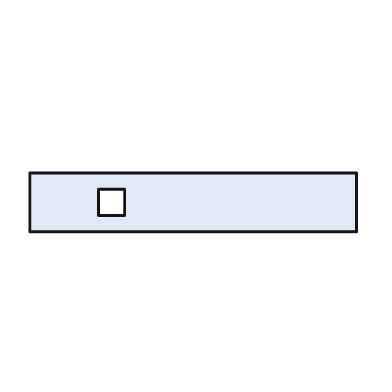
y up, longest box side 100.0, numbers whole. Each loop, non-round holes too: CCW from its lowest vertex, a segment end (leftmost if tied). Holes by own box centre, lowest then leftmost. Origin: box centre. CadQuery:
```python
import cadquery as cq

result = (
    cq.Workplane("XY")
    .moveTo(-50.0, -9.0)
    .lineTo(50.0, -9.0)
    .lineTo(50.0, 9.0)
    .lineTo(-50.0, 9.0)
    .close()
    .moveTo(-29.0, -4.0)
    .lineTo(-21.0, -4.0)
    .lineTo(-21.0, 4.0)
    .lineTo(-29.0, 4.0)
    .close()
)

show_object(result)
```